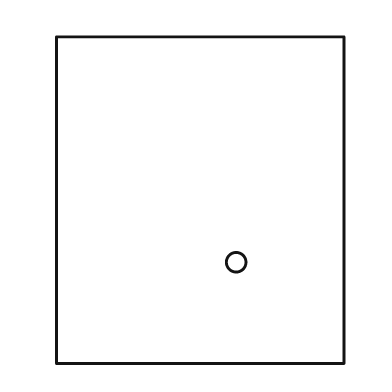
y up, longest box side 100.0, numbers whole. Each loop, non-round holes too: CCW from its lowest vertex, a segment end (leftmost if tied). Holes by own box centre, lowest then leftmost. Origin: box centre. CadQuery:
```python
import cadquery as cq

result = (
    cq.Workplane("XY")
    .moveTo(-44.0, -50.0)
    .lineTo(44.0, -50.0)
    .lineTo(44.0, 50.0)
    .lineTo(-44.0, 50.0)
    .close()
    .moveTo(11.0, -19.0)
    .circle(3.0)
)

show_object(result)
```